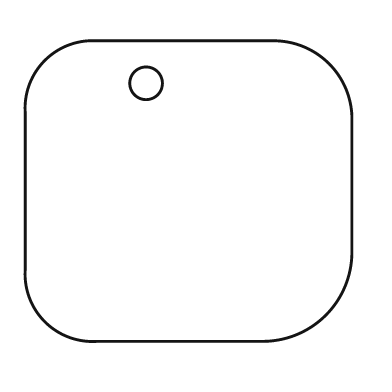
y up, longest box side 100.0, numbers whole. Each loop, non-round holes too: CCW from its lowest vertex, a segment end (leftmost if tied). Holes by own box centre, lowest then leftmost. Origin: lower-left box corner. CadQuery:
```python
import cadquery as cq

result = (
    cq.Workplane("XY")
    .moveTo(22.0, 0.0)
    .lineTo(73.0, 0.0)
    .threePointArc((92.0, 8.0), (100.0, 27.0))
    .lineTo(100.0, 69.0)
    .threePointArc((93.0, 85.0), (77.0, 92.0))
    .lineTo(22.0, 92.0)
    .threePointArc((6.0, 86.0), (0.0, 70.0))
    .lineTo(0.0, 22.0)
    .threePointArc((6.0, 6.0), (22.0, 0.0))
    .close()
    .moveTo(37.0, 79.0)
    .circle(5.0)
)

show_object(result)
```